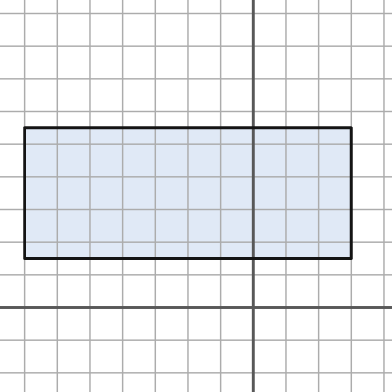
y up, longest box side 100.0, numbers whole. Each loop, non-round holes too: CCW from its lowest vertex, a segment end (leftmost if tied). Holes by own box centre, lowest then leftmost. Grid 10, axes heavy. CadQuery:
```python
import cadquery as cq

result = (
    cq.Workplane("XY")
    .moveTo(-70.0, 15.0)
    .lineTo(30.0, 15.0)
    .lineTo(30.0, 55.0)
    .lineTo(-70.0, 55.0)
    .close()
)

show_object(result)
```